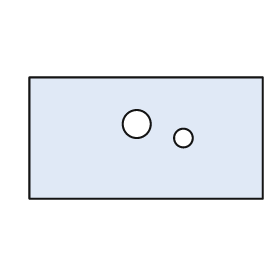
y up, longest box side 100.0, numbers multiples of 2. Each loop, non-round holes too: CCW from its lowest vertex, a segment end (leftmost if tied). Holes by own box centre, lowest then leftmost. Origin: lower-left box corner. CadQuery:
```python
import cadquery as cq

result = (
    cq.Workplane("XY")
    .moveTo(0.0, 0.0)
    .lineTo(100.0, 0.0)
    .lineTo(100.0, 52.0)
    .lineTo(0.0, 52.0)
    .close()
    .moveTo(66.0, 26.0)
    .circle(4.0)
    .moveTo(46.0, 32.0)
    .circle(6.0)
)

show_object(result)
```